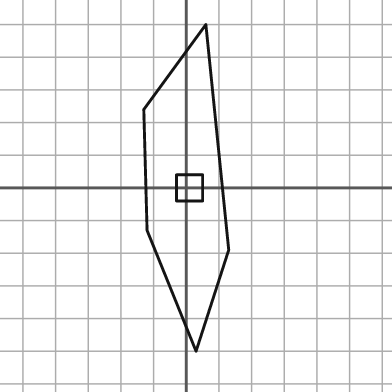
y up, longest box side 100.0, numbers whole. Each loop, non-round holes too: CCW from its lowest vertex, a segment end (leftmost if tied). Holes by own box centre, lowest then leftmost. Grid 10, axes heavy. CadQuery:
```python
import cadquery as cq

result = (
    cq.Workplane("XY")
    .moveTo(3.0, -50.0)
    .lineTo(13.0, -19.0)
    .lineTo(6.0, 50.0)
    .lineTo(-13.0, 24.0)
    .lineTo(-12.0, -13.0)
    .close()
    .moveTo(-3.0, -4.0)
    .lineTo(5.0, -4.0)
    .lineTo(5.0, 4.0)
    .lineTo(-3.0, 4.0)
    .close()
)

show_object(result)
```